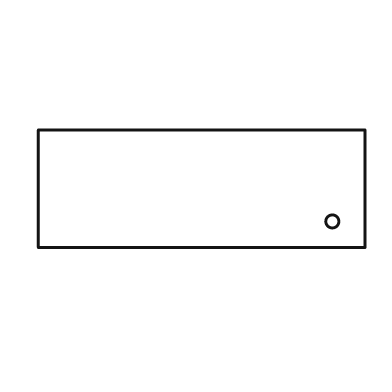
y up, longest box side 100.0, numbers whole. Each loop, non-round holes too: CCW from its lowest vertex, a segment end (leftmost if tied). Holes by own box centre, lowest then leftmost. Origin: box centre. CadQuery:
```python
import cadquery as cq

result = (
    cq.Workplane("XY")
    .moveTo(-50.0, -18.0)
    .lineTo(50.0, -18.0)
    .lineTo(50.0, 18.0)
    .lineTo(-50.0, 18.0)
    .close()
    .moveTo(40.0, -10.0)
    .circle(2.0)
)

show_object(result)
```